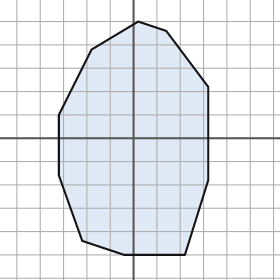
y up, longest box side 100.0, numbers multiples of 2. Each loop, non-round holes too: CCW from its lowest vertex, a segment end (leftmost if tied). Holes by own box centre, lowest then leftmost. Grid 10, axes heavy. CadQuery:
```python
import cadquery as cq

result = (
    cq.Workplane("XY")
    .moveTo(-4.0, -50.0)
    .lineTo(22.0, -50.0)
    .lineTo(32.0, -18.0)
    .lineTo(32.0, 22.0)
    .lineTo(14.0, 46.0)
    .lineTo(2.0, 50.0)
    .lineTo(-18.0, 38.0)
    .lineTo(-32.0, 10.0)
    .lineTo(-32.0, -16.0)
    .lineTo(-22.0, -44.0)
    .close()
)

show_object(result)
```